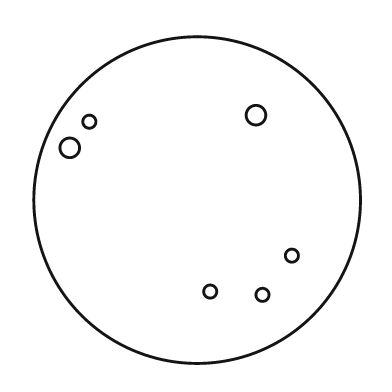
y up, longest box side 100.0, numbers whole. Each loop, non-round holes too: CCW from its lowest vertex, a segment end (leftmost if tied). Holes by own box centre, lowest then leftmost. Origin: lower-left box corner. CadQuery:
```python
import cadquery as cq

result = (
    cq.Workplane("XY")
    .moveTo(50.0, 50.0)
    .circle(50.0)
    .moveTo(70.0, 21.0)
    .circle(2.0)
    .moveTo(54.0, 22.0)
    .circle(2.0)
    .moveTo(79.0, 33.0)
    .circle(2.0)
    .moveTo(11.0, 66.0)
    .circle(3.0)
    .moveTo(17.0, 74.0)
    .circle(2.0)
    .moveTo(68.0, 76.0)
    .circle(3.0)
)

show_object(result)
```